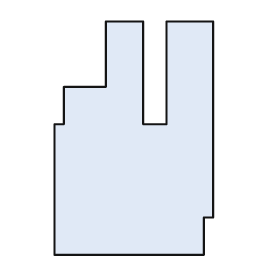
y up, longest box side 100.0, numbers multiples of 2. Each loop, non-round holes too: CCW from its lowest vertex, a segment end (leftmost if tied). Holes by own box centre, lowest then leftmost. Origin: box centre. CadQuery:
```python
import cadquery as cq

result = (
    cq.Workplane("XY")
    .moveTo(-34.0, -50.0)
    .lineTo(30.0, -50.0)
    .lineTo(30.0, -34.0)
    .lineTo(34.0, -34.0)
    .lineTo(34.0, 50.0)
    .lineTo(14.0, 50.0)
    .lineTo(14.0, 6.0)
    .lineTo(4.0, 6.0)
    .lineTo(4.0, 50.0)
    .lineTo(-12.0, 50.0)
    .lineTo(-12.0, 22.0)
    .lineTo(-30.0, 22.0)
    .lineTo(-30.0, 6.0)
    .lineTo(-34.0, 6.0)
    .close()
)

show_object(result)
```